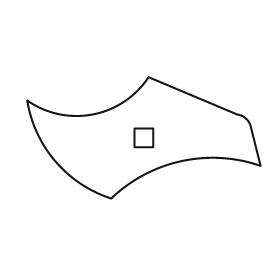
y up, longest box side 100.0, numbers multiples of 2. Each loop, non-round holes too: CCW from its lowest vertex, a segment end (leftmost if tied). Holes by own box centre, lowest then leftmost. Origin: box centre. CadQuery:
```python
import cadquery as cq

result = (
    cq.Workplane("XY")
    .moveTo(-14.0, -26.0)
    .threePointArc((16.0, -10.0), (50.0, -12.0))
    .lineTo(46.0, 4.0)
    .threePointArc((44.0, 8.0), (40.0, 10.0))
    .lineTo(2.0, 26.0)
    .threePointArc((-22.0, 10.0), (-50.0, 16.0))
    .threePointArc((-38.0, -10.0), (-14.0, -26.0))
    .close()
    .moveTo(-4.0, -4.0)
    .lineTo(4.0, -4.0)
    .lineTo(4.0, 4.0)
    .lineTo(-4.0, 4.0)
    .close()
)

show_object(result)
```